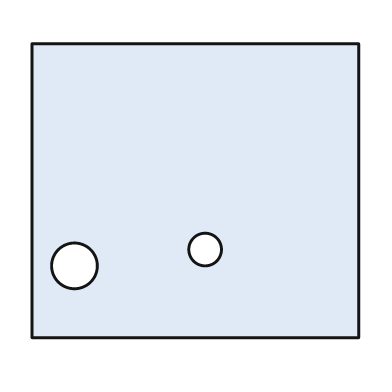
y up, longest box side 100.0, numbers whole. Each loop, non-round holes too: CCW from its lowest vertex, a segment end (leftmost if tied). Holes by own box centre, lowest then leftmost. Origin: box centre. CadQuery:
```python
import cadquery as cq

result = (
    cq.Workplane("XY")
    .moveTo(-50.0, -45.0)
    .lineTo(50.0, -45.0)
    .lineTo(50.0, 45.0)
    .lineTo(-50.0, 45.0)
    .close()
    .moveTo(-37.0, -23.0)
    .circle(7.0)
    .moveTo(3.0, -18.0)
    .circle(5.0)
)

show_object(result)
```